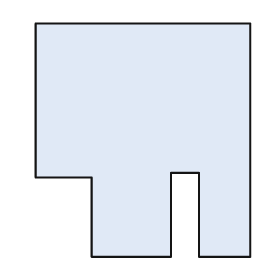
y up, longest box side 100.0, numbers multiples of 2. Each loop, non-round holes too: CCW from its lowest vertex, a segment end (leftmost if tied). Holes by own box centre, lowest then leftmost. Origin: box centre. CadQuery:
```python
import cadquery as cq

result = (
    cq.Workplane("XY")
    .moveTo(-22.0, -50.0)
    .lineTo(12.0, -50.0)
    .lineTo(12.0, -14.0)
    .lineTo(24.0, -14.0)
    .lineTo(24.0, -50.0)
    .lineTo(46.0, -50.0)
    .lineTo(46.0, 50.0)
    .lineTo(-46.0, 50.0)
    .lineTo(-46.0, -16.0)
    .lineTo(-22.0, -16.0)
    .close()
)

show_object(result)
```